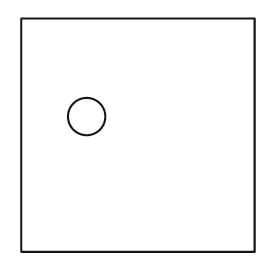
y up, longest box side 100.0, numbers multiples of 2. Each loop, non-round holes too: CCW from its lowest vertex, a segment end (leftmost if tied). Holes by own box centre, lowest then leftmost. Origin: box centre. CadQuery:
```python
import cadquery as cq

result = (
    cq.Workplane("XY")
    .moveTo(-50.0, -50.0)
    .lineTo(50.0, -50.0)
    .lineTo(50.0, 50.0)
    .lineTo(-50.0, 50.0)
    .close()
    .moveTo(-22.0, 8.0)
    .circle(8.0)
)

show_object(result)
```